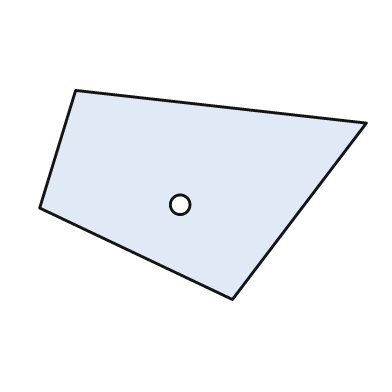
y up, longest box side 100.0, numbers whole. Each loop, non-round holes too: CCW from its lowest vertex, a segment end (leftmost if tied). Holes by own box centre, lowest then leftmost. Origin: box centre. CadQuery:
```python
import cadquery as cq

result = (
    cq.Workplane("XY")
    .moveTo(9.0, -32.0)
    .lineTo(50.0, 22.0)
    .lineTo(-39.0, 32.0)
    .lineTo(-50.0, -4.0)
    .close()
    .moveTo(-7.0, -3.0)
    .circle(3.0)
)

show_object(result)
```